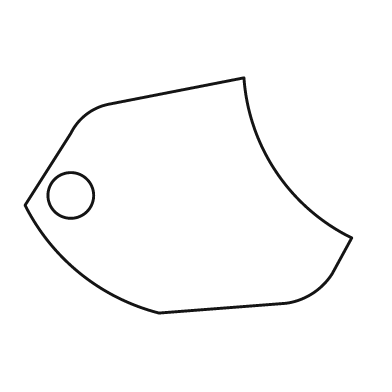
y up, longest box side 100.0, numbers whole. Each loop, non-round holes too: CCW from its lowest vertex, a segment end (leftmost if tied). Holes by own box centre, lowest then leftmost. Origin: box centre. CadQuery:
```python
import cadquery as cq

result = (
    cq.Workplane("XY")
    .moveTo(-9.0, -36.0)
    .lineTo(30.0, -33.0)
    .threePointArc((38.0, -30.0), (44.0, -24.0))
    .lineTo(50.0, -13.0)
    .threePointArc((27.0, 7.0), (17.0, 36.0))
    .lineTo(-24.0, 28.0)
    .threePointArc((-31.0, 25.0), (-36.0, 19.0))
    .lineTo(-50.0, -3.0)
    .threePointArc((-33.0, -24.0), (-9.0, -36.0))
    .close()
    .moveTo(-36.0, 0.0)
    .circle(7.0)
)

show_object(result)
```